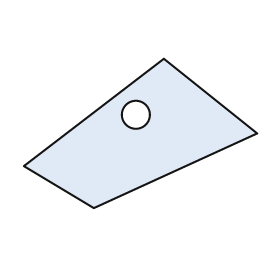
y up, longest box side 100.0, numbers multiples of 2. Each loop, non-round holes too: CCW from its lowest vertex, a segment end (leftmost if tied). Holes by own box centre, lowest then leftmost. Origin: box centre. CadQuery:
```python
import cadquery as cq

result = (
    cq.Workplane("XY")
    .moveTo(-20.0, -32.0)
    .lineTo(50.0, 0.0)
    .lineTo(10.0, 32.0)
    .lineTo(-50.0, -14.0)
    .close()
    .moveTo(-2.0, 8.0)
    .circle(6.0)
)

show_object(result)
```